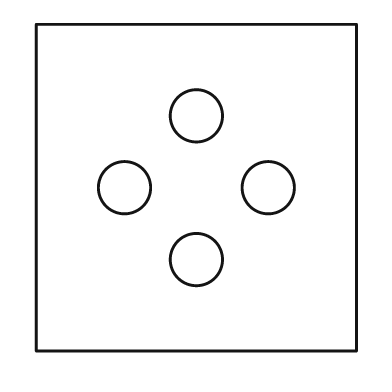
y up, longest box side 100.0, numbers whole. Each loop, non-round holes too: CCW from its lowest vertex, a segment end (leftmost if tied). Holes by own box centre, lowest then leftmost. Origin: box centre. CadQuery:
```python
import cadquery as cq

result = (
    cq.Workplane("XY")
    .moveTo(-49.0, -50.0)
    .lineTo(49.0, -50.0)
    .lineTo(49.0, 50.0)
    .lineTo(-49.0, 50.0)
    .close()
    .moveTo(0.0, -22.0)
    .circle(8.0)
    .moveTo(-22.0, 0.0)
    .circle(8.0)
    .moveTo(22.0, 0.0)
    .circle(8.0)
    .moveTo(0.0, 22.0)
    .circle(8.0)
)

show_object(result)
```